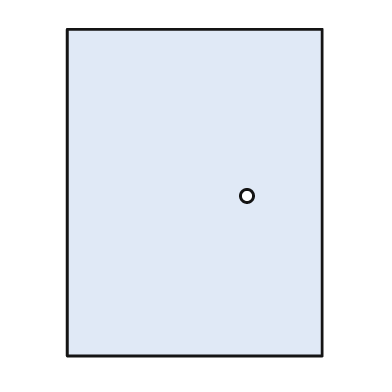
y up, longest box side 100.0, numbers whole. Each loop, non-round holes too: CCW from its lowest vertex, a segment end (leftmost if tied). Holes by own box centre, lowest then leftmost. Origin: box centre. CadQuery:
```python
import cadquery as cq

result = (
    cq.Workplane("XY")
    .moveTo(-39.0, -50.0)
    .lineTo(39.0, -50.0)
    .lineTo(39.0, 50.0)
    .lineTo(-39.0, 50.0)
    .close()
    .moveTo(16.0, -1.0)
    .circle(2.0)
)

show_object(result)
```